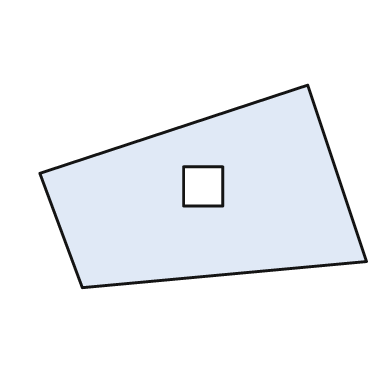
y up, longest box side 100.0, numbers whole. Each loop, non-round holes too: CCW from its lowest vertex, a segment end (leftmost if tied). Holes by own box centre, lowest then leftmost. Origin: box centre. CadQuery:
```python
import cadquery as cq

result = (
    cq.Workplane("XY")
    .moveTo(-37.0, -31.0)
    .lineTo(50.0, -23.0)
    .lineTo(32.0, 31.0)
    .lineTo(-50.0, 4.0)
    .close()
    .moveTo(-6.0, -6.0)
    .lineTo(6.0, -6.0)
    .lineTo(6.0, 6.0)
    .lineTo(-6.0, 6.0)
    .close()
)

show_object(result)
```